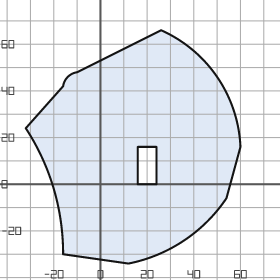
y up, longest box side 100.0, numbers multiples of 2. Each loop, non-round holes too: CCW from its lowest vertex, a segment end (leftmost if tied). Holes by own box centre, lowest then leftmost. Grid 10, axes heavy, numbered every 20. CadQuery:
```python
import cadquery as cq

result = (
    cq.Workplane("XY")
    .moveTo(12.0, -34.0)
    .threePointArc((36.0, -24.0), (54.0, -6.0))
    .lineTo(60.0, 16.0)
    .threePointArc((50.0, 46.0), (26.0, 66.0))
    .lineTo(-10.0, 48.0)
    .threePointArc((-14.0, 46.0), (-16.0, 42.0))
    .lineTo(-32.0, 24.0)
    .threePointArc((-20.0, -2.0), (-16.0, -30.0))
    .close()
    .moveTo(16.0, 0.0)
    .lineTo(24.0, 0.0)
    .lineTo(24.0, 16.0)
    .lineTo(16.0, 16.0)
    .close()
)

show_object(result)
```